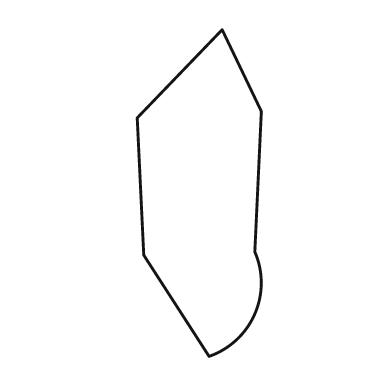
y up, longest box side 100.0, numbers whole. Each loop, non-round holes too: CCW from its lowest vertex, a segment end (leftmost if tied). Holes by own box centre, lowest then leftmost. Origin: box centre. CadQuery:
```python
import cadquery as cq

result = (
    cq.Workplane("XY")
    .moveTo(3.0, -50.0)
    .threePointArc((17.0, -37.0), (17.0, -18.0))
    .lineTo(19.0, 25.0)
    .lineTo(7.0, 50.0)
    .lineTo(-19.0, 23.0)
    .lineTo(-17.0, -19.0)
    .close()
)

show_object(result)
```